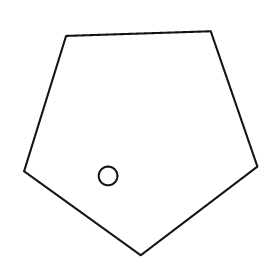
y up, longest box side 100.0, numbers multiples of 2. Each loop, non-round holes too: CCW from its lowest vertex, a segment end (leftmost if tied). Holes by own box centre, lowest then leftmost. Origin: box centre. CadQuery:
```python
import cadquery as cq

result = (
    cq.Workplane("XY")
    .moveTo(0.0, -48.0)
    .lineTo(50.0, -10.0)
    .lineTo(30.0, 48.0)
    .lineTo(-32.0, 46.0)
    .lineTo(-50.0, -12.0)
    .close()
    .moveTo(-14.0, -14.0)
    .circle(4.0)
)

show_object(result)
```